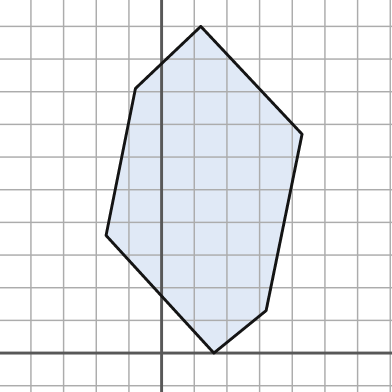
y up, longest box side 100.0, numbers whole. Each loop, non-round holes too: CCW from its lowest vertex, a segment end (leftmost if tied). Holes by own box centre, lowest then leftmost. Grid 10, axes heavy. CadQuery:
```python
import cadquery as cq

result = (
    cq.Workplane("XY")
    .moveTo(16.0, 0.0)
    .lineTo(32.0, 13.0)
    .lineTo(43.0, 67.0)
    .lineTo(12.0, 100.0)
    .lineTo(-8.0, 81.0)
    .lineTo(-17.0, 36.0)
    .close()
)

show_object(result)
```